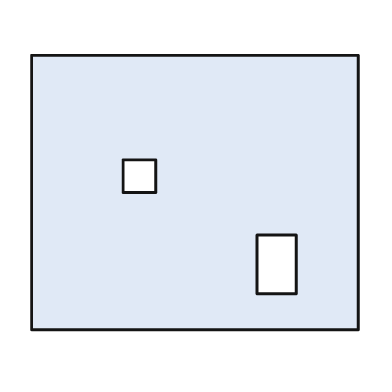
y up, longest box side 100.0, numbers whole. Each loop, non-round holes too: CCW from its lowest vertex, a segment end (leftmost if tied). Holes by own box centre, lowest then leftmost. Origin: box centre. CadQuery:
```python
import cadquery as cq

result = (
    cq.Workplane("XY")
    .moveTo(-50.0, -42.0)
    .lineTo(50.0, -42.0)
    .lineTo(50.0, 42.0)
    .lineTo(-50.0, 42.0)
    .close()
    .moveTo(19.0, -31.0)
    .lineTo(31.0, -31.0)
    .lineTo(31.0, -13.0)
    .lineTo(19.0, -13.0)
    .close()
    .moveTo(-22.0, 0.0)
    .lineTo(-12.0, 0.0)
    .lineTo(-12.0, 10.0)
    .lineTo(-22.0, 10.0)
    .close()
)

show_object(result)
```